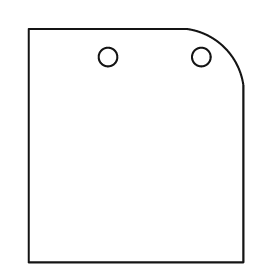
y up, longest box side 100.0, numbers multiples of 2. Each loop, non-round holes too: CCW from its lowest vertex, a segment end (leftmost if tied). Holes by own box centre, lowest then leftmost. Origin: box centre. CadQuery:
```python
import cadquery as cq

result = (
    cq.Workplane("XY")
    .moveTo(-46.0, -50.0)
    .lineTo(46.0, -50.0)
    .lineTo(46.0, 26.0)
    .threePointArc((38.0, 42.0), (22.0, 50.0))
    .lineTo(-46.0, 50.0)
    .close()
    .moveTo(-12.0, 38.0)
    .circle(4.0)
    .moveTo(28.0, 38.0)
    .circle(4.0)
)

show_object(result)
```